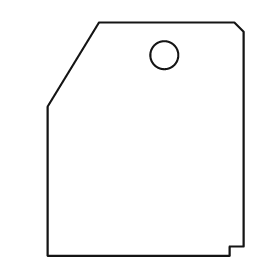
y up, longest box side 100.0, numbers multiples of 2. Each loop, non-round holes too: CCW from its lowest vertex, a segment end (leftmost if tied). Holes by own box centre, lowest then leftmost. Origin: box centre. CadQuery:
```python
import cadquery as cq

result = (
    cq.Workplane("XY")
    .moveTo(-42.0, -50.0)
    .lineTo(36.0, -50.0)
    .lineTo(36.0, -46.0)
    .lineTo(42.0, -46.0)
    .lineTo(42.0, 46.0)
    .lineTo(38.0, 50.0)
    .lineTo(-20.0, 50.0)
    .lineTo(-42.0, 14.0)
    .close()
    .moveTo(8.0, 36.0)
    .circle(6.0)
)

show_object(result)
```